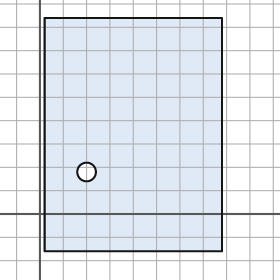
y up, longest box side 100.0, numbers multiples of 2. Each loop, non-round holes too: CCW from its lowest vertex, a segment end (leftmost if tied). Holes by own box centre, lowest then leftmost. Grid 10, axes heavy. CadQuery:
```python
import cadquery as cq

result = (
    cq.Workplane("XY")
    .moveTo(2.0, -16.0)
    .lineTo(78.0, -16.0)
    .lineTo(78.0, 84.0)
    .lineTo(2.0, 84.0)
    .close()
    .moveTo(20.0, 18.0)
    .circle(4.0)
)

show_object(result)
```